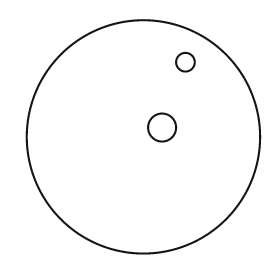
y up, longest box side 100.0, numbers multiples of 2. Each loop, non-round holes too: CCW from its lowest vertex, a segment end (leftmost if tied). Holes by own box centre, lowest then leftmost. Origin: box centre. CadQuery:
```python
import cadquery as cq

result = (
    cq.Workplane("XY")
    .moveTo(0.0, 0.0)
    .circle(50.0)
    .moveTo(8.0, 4.0)
    .circle(6.0)
    .moveTo(18.0, 32.0)
    .circle(4.0)
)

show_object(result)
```